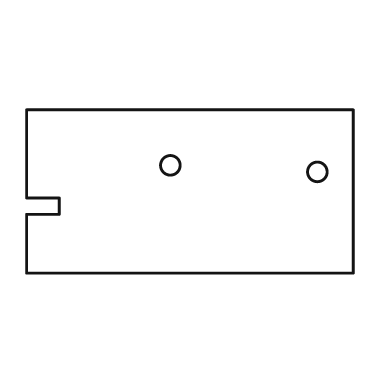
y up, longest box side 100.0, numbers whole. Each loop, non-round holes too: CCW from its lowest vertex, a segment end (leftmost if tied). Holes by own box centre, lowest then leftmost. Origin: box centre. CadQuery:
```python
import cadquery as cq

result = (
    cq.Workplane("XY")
    .moveTo(-50.0, -25.0)
    .lineTo(50.0, -25.0)
    .lineTo(50.0, 25.0)
    .lineTo(-50.0, 25.0)
    .lineTo(-50.0, -2.0)
    .lineTo(-40.0, -2.0)
    .lineTo(-40.0, -7.0)
    .lineTo(-50.0, -7.0)
    .close()
    .moveTo(39.0, 6.0)
    .circle(3.0)
    .moveTo(-6.0, 8.0)
    .circle(3.0)
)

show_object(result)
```